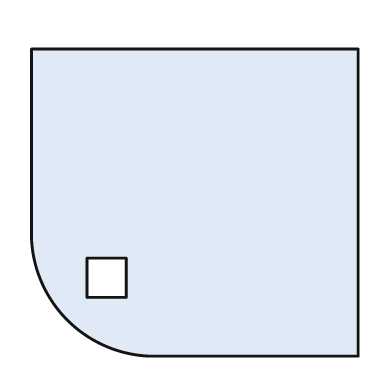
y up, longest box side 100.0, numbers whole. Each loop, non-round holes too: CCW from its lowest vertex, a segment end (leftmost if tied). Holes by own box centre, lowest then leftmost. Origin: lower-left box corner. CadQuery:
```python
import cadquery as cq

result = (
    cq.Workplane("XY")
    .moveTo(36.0, 0.0)
    .lineTo(100.0, 0.0)
    .lineTo(100.0, 94.0)
    .lineTo(0.0, 94.0)
    .lineTo(0.0, 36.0)
    .threePointArc((11.0, 11.0), (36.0, 0.0))
    .close()
    .moveTo(17.0, 18.0)
    .lineTo(29.0, 18.0)
    .lineTo(29.0, 30.0)
    .lineTo(17.0, 30.0)
    .close()
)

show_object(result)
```